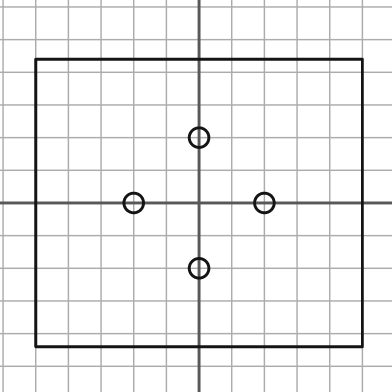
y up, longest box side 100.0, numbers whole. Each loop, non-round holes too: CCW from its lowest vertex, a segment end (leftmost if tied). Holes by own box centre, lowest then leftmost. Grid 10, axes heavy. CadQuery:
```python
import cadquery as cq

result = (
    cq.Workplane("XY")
    .moveTo(-50.0, -44.0)
    .lineTo(50.0, -44.0)
    .lineTo(50.0, 44.0)
    .lineTo(-50.0, 44.0)
    .close()
    .moveTo(0.0, -20.0)
    .circle(3.0)
    .moveTo(-20.0, 0.0)
    .circle(3.0)
    .moveTo(20.0, 0.0)
    .circle(3.0)
    .moveTo(0.0, 20.0)
    .circle(3.0)
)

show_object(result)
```